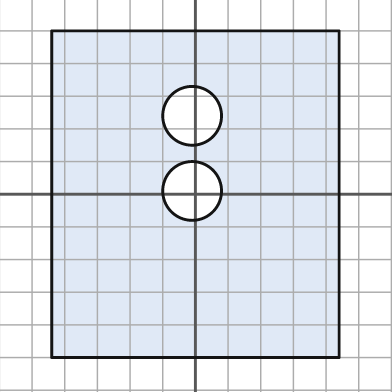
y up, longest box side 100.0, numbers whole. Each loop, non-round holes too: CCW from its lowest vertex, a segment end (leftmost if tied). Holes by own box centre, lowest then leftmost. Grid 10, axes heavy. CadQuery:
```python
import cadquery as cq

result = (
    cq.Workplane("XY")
    .moveTo(-44.0, -50.0)
    .lineTo(44.0, -50.0)
    .lineTo(44.0, 50.0)
    .lineTo(-44.0, 50.0)
    .close()
    .moveTo(-1.0, 1.0)
    .circle(9.0)
    .moveTo(-1.0, 24.0)
    .circle(9.0)
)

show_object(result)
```